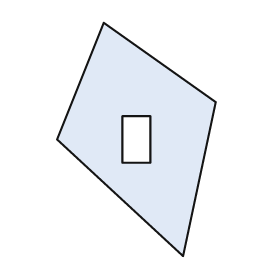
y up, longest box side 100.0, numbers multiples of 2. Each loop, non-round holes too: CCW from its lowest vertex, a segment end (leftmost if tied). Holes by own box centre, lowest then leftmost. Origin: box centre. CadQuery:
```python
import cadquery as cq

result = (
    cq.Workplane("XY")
    .moveTo(20.0, -50.0)
    .lineTo(34.0, 16.0)
    .lineTo(-14.0, 50.0)
    .lineTo(-34.0, 0.0)
    .close()
    .moveTo(-6.0, -10.0)
    .lineTo(6.0, -10.0)
    .lineTo(6.0, 10.0)
    .lineTo(-6.0, 10.0)
    .close()
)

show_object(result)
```